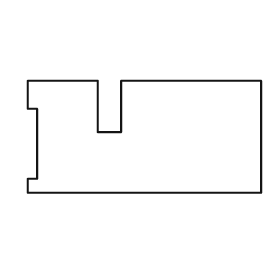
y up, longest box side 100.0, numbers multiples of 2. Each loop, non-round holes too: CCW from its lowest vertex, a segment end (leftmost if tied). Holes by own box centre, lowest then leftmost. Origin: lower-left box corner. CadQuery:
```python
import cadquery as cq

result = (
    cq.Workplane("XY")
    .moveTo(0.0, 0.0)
    .lineTo(100.0, 0.0)
    .lineTo(100.0, 48.0)
    .lineTo(40.0, 48.0)
    .lineTo(40.0, 26.0)
    .lineTo(30.0, 26.0)
    .lineTo(30.0, 48.0)
    .lineTo(0.0, 48.0)
    .lineTo(0.0, 36.0)
    .lineTo(4.0, 36.0)
    .lineTo(4.0, 6.0)
    .lineTo(0.0, 6.0)
    .close()
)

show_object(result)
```